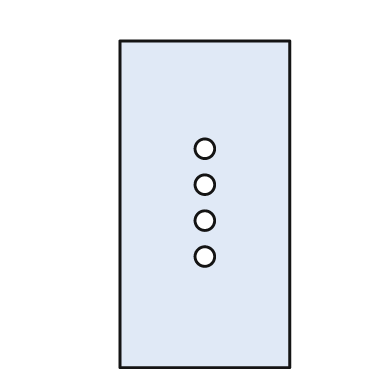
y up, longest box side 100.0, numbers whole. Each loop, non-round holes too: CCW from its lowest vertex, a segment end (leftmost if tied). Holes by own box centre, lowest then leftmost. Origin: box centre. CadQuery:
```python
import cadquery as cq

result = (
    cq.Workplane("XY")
    .moveTo(-26.0, -50.0)
    .lineTo(26.0, -50.0)
    .lineTo(26.0, 50.0)
    .lineTo(-26.0, 50.0)
    .close()
    .moveTo(0.0, -16.0)
    .circle(3.0)
    .moveTo(0.0, -5.0)
    .circle(3.0)
    .moveTo(0.0, 6.0)
    .circle(3.0)
    .moveTo(0.0, 17.0)
    .circle(3.0)
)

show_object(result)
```